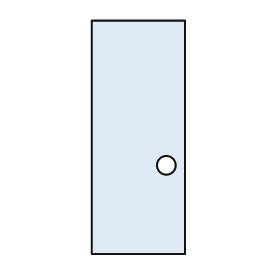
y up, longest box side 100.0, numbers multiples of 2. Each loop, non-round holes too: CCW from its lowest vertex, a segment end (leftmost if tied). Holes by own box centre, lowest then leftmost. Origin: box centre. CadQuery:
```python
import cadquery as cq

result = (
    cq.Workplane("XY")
    .moveTo(-20.0, -50.0)
    .lineTo(20.0, -50.0)
    .lineTo(20.0, 50.0)
    .lineTo(-20.0, 50.0)
    .close()
    .moveTo(12.0, -12.0)
    .circle(4.0)
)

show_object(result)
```